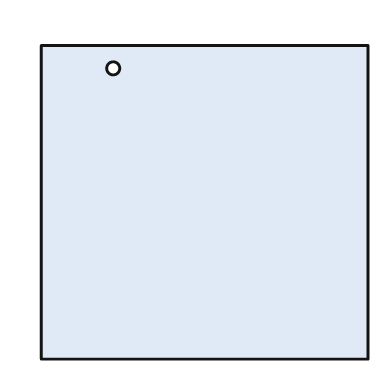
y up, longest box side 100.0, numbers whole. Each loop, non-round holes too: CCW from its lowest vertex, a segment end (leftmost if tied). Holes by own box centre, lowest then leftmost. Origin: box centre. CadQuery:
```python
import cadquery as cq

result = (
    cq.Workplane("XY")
    .moveTo(-50.0, -48.0)
    .lineTo(50.0, -48.0)
    .lineTo(50.0, 48.0)
    .lineTo(-50.0, 48.0)
    .close()
    .moveTo(-28.0, 41.0)
    .circle(2.0)
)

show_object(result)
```